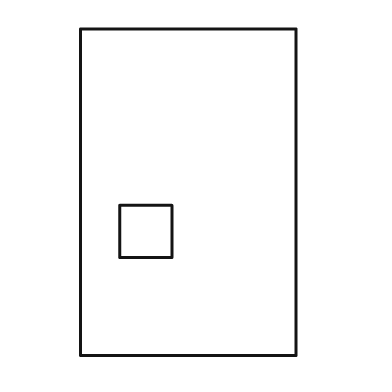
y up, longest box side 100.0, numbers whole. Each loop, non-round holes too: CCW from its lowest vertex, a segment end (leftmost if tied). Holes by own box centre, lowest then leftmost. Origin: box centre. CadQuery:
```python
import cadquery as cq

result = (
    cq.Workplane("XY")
    .moveTo(-33.0, -50.0)
    .lineTo(33.0, -50.0)
    .lineTo(33.0, 50.0)
    .lineTo(-33.0, 50.0)
    .close()
    .moveTo(-21.0, -20.0)
    .lineTo(-5.0, -20.0)
    .lineTo(-5.0, -4.0)
    .lineTo(-21.0, -4.0)
    .close()
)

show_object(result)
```